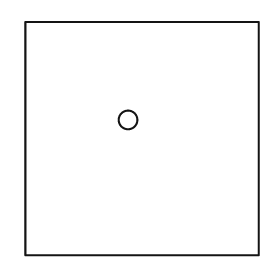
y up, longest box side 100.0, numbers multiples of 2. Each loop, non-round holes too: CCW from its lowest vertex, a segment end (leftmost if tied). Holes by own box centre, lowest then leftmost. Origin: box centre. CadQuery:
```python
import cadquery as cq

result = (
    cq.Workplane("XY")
    .moveTo(-50.0, -50.0)
    .lineTo(50.0, -50.0)
    .lineTo(50.0, 50.0)
    .lineTo(-50.0, 50.0)
    .close()
    .moveTo(-6.0, 8.0)
    .circle(4.0)
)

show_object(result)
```